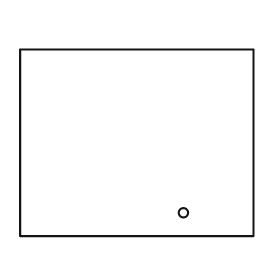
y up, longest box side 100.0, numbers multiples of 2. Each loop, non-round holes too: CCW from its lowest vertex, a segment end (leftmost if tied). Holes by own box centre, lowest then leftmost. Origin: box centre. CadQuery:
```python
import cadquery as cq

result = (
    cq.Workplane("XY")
    .moveTo(-50.0, -40.0)
    .lineTo(50.0, -40.0)
    .lineTo(50.0, 40.0)
    .lineTo(-50.0, 40.0)
    .close()
    .moveTo(20.0, -30.0)
    .circle(2.0)
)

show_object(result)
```